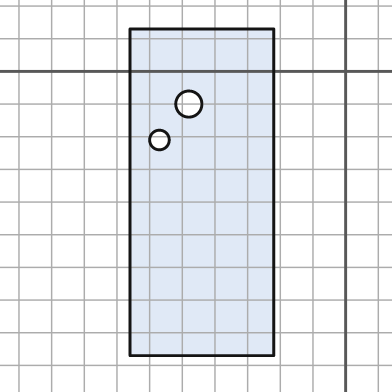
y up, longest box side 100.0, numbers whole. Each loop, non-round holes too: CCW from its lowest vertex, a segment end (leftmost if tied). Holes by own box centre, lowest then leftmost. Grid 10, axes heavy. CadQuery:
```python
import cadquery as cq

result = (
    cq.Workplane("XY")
    .moveTo(-66.0, -87.0)
    .lineTo(-22.0, -87.0)
    .lineTo(-22.0, 13.0)
    .lineTo(-66.0, 13.0)
    .close()
    .moveTo(-57.0, -21.0)
    .circle(3.0)
    .moveTo(-48.0, -10.0)
    .circle(4.0)
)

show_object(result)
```